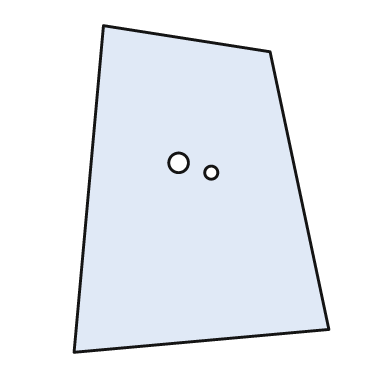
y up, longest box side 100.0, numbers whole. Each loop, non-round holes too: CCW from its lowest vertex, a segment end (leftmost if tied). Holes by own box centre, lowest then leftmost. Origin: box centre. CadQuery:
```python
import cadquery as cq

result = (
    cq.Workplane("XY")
    .moveTo(-39.0, -50.0)
    .lineTo(39.0, -43.0)
    .lineTo(21.0, 42.0)
    .lineTo(-30.0, 50.0)
    .close()
    .moveTo(3.0, 5.0)
    .circle(2.0)
    .moveTo(-7.0, 8.0)
    .circle(3.0)
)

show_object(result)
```